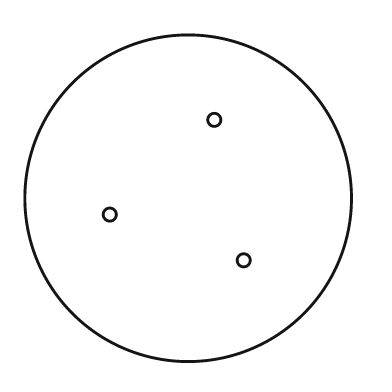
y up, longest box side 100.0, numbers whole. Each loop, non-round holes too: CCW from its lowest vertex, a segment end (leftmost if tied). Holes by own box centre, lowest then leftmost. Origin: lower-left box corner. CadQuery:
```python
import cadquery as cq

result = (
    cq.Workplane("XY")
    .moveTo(50.0, 50.0)
    .circle(50.0)
    .moveTo(67.0, 31.0)
    .circle(2.0)
    .moveTo(26.0, 45.0)
    .circle(2.0)
    .moveTo(58.0, 74.0)
    .circle(2.0)
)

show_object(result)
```